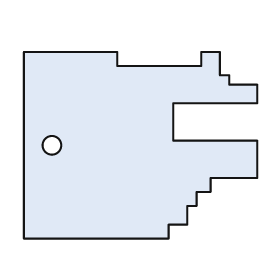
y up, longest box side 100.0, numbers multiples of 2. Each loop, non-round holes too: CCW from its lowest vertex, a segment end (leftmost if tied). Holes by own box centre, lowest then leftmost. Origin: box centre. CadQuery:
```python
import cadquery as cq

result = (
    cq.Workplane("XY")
    .moveTo(-50.0, -40.0)
    .lineTo(12.0, -40.0)
    .lineTo(12.0, -34.0)
    .lineTo(20.0, -34.0)
    .lineTo(20.0, -26.0)
    .lineTo(24.0, -26.0)
    .lineTo(24.0, -20.0)
    .lineTo(30.0, -20.0)
    .lineTo(30.0, -14.0)
    .lineTo(50.0, -14.0)
    .lineTo(50.0, 2.0)
    .lineTo(14.0, 2.0)
    .lineTo(14.0, 18.0)
    .lineTo(50.0, 18.0)
    .lineTo(50.0, 26.0)
    .lineTo(38.0, 26.0)
    .lineTo(38.0, 30.0)
    .lineTo(34.0, 30.0)
    .lineTo(34.0, 40.0)
    .lineTo(26.0, 40.0)
    .lineTo(26.0, 34.0)
    .lineTo(-10.0, 34.0)
    .lineTo(-10.0, 40.0)
    .lineTo(-50.0, 40.0)
    .close()
    .moveTo(-38.0, 0.0)
    .circle(4.0)
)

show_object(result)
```